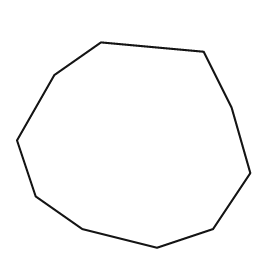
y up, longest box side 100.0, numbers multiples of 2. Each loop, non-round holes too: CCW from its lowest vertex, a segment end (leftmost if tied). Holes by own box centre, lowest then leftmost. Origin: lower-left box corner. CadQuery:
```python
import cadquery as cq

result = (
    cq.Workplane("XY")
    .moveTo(60.0, 0.0)
    .lineTo(84.0, 8.0)
    .lineTo(100.0, 32.0)
    .lineTo(92.0, 60.0)
    .lineTo(80.0, 84.0)
    .lineTo(36.0, 88.0)
    .lineTo(16.0, 74.0)
    .lineTo(0.0, 46.0)
    .lineTo(8.0, 22.0)
    .lineTo(28.0, 8.0)
    .close()
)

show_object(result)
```